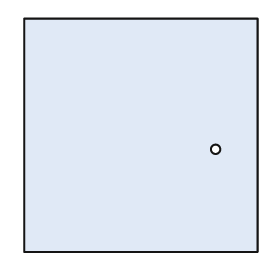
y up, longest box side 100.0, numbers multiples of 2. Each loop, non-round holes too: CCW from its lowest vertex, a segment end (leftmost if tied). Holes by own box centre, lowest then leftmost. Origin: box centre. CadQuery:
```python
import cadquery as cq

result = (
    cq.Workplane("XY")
    .moveTo(-50.0, -50.0)
    .lineTo(50.0, -50.0)
    .lineTo(50.0, 50.0)
    .lineTo(-50.0, 50.0)
    .close()
    .moveTo(32.0, -6.0)
    .circle(2.0)
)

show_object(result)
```